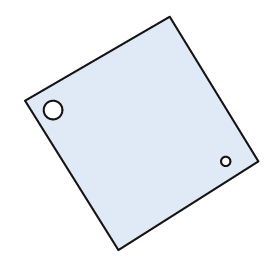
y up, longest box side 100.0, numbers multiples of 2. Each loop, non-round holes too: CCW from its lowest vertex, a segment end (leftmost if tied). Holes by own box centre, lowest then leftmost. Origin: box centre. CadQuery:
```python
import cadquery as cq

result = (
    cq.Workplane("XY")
    .moveTo(-10.0, -50.0)
    .lineTo(50.0, -12.0)
    .lineTo(12.0, 50.0)
    .lineTo(-50.0, 14.0)
    .close()
    .moveTo(36.0, -12.0)
    .circle(2.0)
    .moveTo(-38.0, 10.0)
    .circle(4.0)
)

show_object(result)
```